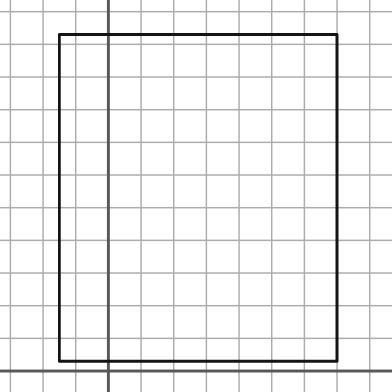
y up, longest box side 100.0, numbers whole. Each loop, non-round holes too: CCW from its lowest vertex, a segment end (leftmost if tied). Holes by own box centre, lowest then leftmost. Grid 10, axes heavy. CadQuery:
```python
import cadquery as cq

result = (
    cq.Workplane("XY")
    .moveTo(-15.0, 3.0)
    .lineTo(70.0, 3.0)
    .lineTo(70.0, 103.0)
    .lineTo(-15.0, 103.0)
    .close()
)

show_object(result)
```